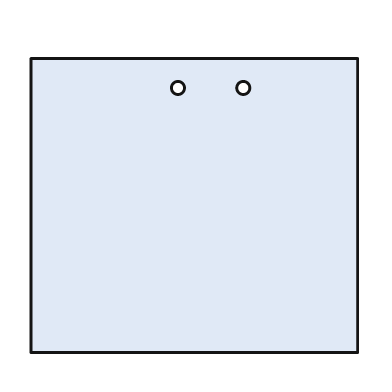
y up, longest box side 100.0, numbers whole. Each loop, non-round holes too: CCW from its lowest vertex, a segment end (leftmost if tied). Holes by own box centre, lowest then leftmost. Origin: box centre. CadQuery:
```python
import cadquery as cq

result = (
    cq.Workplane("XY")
    .moveTo(-50.0, -45.0)
    .lineTo(50.0, -45.0)
    .lineTo(50.0, 45.0)
    .lineTo(-50.0, 45.0)
    .close()
    .moveTo(-5.0, 36.0)
    .circle(2.0)
    .moveTo(15.0, 36.0)
    .circle(2.0)
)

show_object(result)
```